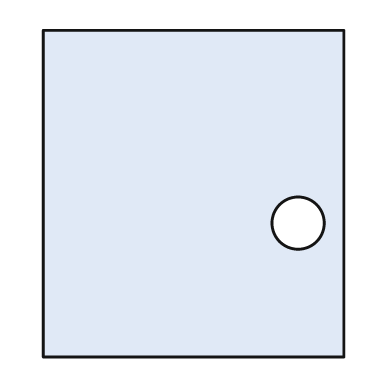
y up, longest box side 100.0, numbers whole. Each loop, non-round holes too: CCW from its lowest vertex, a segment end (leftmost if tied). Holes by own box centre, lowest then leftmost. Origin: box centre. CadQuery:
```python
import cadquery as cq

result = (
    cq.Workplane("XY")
    .moveTo(-46.0, -50.0)
    .lineTo(46.0, -50.0)
    .lineTo(46.0, 50.0)
    .lineTo(-46.0, 50.0)
    .close()
    .moveTo(32.0, -9.0)
    .circle(8.0)
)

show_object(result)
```